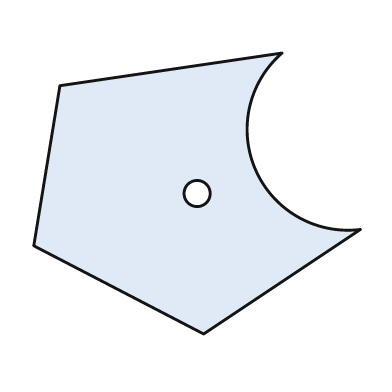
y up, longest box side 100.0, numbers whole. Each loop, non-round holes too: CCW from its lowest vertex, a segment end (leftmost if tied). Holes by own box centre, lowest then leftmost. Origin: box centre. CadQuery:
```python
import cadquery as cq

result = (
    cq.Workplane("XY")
    .moveTo(2.0, -43.0)
    .lineTo(50.0, -11.0)
    .threePointArc((18.0, 7.0), (26.0, 43.0))
    .lineTo(-42.0, 33.0)
    .lineTo(-50.0, -16.0)
    .close()
    .moveTo(0.0, 0.0)
    .circle(4.0)
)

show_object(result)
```